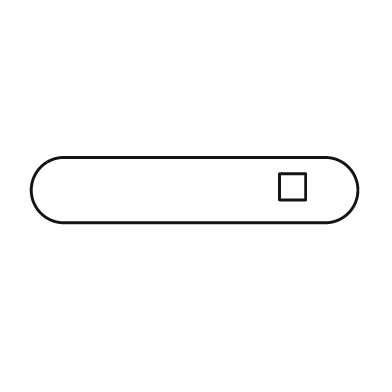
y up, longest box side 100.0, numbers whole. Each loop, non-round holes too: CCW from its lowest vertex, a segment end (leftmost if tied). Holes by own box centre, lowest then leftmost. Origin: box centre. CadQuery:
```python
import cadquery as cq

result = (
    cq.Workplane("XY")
    .moveTo(-40.0, -10.0)
    .lineTo(40.0, -10.0)
    .threePointArc((50.0, 0.0), (40.0, 10.0))
    .lineTo(-40.0, 10.0)
    .threePointArc((-50.0, 0.0), (-40.0, -10.0))
    .close()
    .moveTo(26.0, -3.0)
    .lineTo(34.0, -3.0)
    .lineTo(34.0, 5.0)
    .lineTo(26.0, 5.0)
    .close()
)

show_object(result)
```